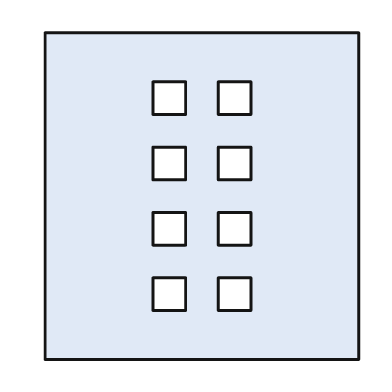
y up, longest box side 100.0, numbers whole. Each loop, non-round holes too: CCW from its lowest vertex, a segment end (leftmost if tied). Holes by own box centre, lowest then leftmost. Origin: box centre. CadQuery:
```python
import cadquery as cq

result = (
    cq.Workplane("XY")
    .moveTo(-48.0, -50.0)
    .lineTo(48.0, -50.0)
    .lineTo(48.0, 50.0)
    .lineTo(-48.0, 50.0)
    .close()
    .moveTo(-15.0, -35.0)
    .lineTo(-5.0, -35.0)
    .lineTo(-5.0, -25.0)
    .lineTo(-15.0, -25.0)
    .close()
    .moveTo(5.0, -35.0)
    .lineTo(15.0, -35.0)
    .lineTo(15.0, -25.0)
    .lineTo(5.0, -25.0)
    .close()
    .moveTo(-15.0, -15.0)
    .lineTo(-5.0, -15.0)
    .lineTo(-5.0, -5.0)
    .lineTo(-15.0, -5.0)
    .close()
    .moveTo(5.0, -15.0)
    .lineTo(15.0, -15.0)
    .lineTo(15.0, -5.0)
    .lineTo(5.0, -5.0)
    .close()
    .moveTo(-15.0, 5.0)
    .lineTo(-5.0, 5.0)
    .lineTo(-5.0, 15.0)
    .lineTo(-15.0, 15.0)
    .close()
    .moveTo(5.0, 5.0)
    .lineTo(15.0, 5.0)
    .lineTo(15.0, 15.0)
    .lineTo(5.0, 15.0)
    .close()
    .moveTo(-15.0, 25.0)
    .lineTo(-5.0, 25.0)
    .lineTo(-5.0, 35.0)
    .lineTo(-15.0, 35.0)
    .close()
    .moveTo(5.0, 25.0)
    .lineTo(15.0, 25.0)
    .lineTo(15.0, 35.0)
    .lineTo(5.0, 35.0)
    .close()
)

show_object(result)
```